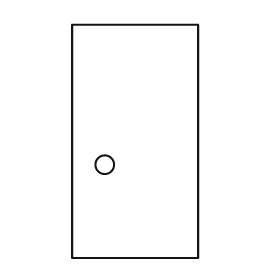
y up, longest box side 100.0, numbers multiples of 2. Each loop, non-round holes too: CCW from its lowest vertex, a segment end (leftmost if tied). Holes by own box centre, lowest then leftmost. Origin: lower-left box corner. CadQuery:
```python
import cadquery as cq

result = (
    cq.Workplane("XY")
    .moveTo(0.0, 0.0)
    .lineTo(54.0, 0.0)
    .lineTo(54.0, 100.0)
    .lineTo(0.0, 100.0)
    .close()
    .moveTo(14.0, 40.0)
    .circle(4.0)
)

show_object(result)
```